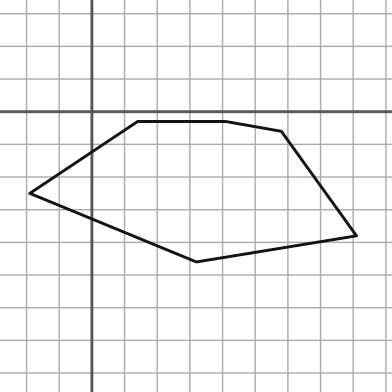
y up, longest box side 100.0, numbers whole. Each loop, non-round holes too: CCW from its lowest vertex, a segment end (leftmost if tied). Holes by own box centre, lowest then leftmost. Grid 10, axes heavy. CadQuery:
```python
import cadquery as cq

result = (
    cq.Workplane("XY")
    .moveTo(32.0, -46.0)
    .lineTo(81.0, -38.0)
    .lineTo(58.0, -6.0)
    .lineTo(41.0, -3.0)
    .lineTo(14.0, -3.0)
    .lineTo(-19.0, -25.0)
    .close()
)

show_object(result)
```